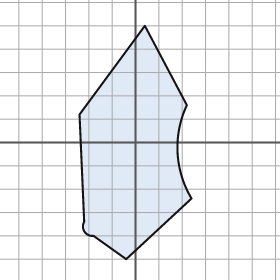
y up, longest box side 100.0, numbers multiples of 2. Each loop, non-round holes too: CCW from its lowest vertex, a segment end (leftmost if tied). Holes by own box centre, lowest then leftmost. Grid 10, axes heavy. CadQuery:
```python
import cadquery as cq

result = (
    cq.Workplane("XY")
    .moveTo(-4.0, -50.0)
    .lineTo(24.0, -24.0)
    .threePointArc((18.0, -4.0), (22.0, 16.0))
    .lineTo(4.0, 50.0)
    .lineTo(-24.0, 12.0)
    .lineTo(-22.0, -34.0)
    .threePointArc((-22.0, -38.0), (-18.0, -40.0))
    .close()
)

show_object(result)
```